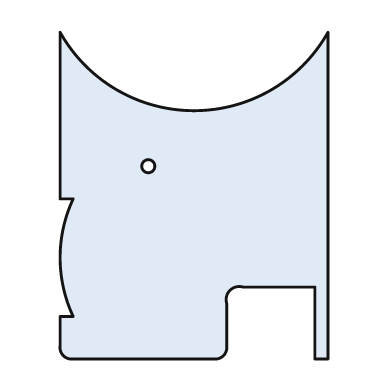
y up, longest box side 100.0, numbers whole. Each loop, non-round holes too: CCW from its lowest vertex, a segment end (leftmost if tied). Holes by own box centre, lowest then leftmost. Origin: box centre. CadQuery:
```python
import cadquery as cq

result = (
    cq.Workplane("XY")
    .moveTo(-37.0, -50.0)
    .lineTo(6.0, -50.0)
    .threePointArc((9.0, -49.0), (10.0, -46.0))
    .lineTo(10.0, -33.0)
    .threePointArc((11.0, -29.0), (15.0, -28.0))
    .lineTo(37.0, -28.0)
    .lineTo(37.0, -50.0)
    .lineTo(41.0, -50.0)
    .lineTo(41.0, 50.0)
    .threePointArc((0.0, 26.0), (-41.0, 50.0))
    .lineTo(-41.0, -1.0)
    .lineTo(-37.0, -1.0)
    .threePointArc((-41.0, -19.0), (-37.0, -37.0))
    .lineTo(-41.0, -37.0)
    .lineTo(-41.0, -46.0)
    .threePointArc((-40.0, -49.0), (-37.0, -50.0))
    .close()
    .moveTo(-14.0, 9.0)
    .circle(2.0)
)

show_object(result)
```